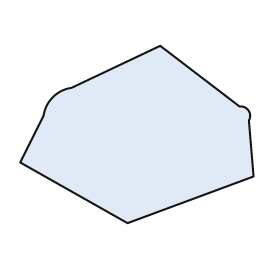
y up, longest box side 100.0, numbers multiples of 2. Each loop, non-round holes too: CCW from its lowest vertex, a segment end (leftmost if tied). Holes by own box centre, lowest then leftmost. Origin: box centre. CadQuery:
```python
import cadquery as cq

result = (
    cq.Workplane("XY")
    .moveTo(-4.0, -38.0)
    .lineTo(50.0, -18.0)
    .lineTo(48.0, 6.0)
    .threePointArc((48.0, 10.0), (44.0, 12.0))
    .lineTo(10.0, 38.0)
    .lineTo(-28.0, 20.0)
    .threePointArc((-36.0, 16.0), (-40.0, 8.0))
    .lineTo(-50.0, -12.0)
    .close()
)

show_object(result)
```